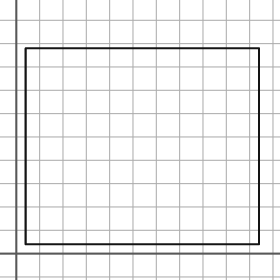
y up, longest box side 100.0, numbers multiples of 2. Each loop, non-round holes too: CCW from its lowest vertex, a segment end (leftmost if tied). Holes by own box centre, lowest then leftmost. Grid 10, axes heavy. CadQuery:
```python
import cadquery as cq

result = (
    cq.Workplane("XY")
    .moveTo(4.0, 4.0)
    .lineTo(104.0, 4.0)
    .lineTo(104.0, 88.0)
    .lineTo(4.0, 88.0)
    .close()
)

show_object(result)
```